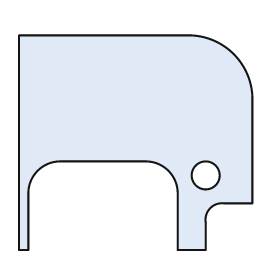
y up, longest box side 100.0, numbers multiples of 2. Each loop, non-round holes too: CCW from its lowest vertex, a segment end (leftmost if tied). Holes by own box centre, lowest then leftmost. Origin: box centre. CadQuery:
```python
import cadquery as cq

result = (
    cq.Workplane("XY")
    .moveTo(-50.0, -46.0)
    .lineTo(-46.0, -46.0)
    .lineTo(-46.0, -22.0)
    .threePointArc((-42.0, -12.0), (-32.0, -8.0))
    .lineTo(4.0, -8.0)
    .threePointArc((14.0, -12.0), (18.0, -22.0))
    .lineTo(18.0, -46.0)
    .lineTo(30.0, -46.0)
    .lineTo(30.0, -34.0)
    .threePointArc((32.0, -28.0), (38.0, -26.0))
    .lineTo(50.0, -26.0)
    .lineTo(50.0, 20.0)
    .threePointArc((42.0, 38.0), (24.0, 46.0))
    .lineTo(-50.0, 46.0)
    .close()
    .moveTo(30.0, -14.0)
    .circle(6.0)
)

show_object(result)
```